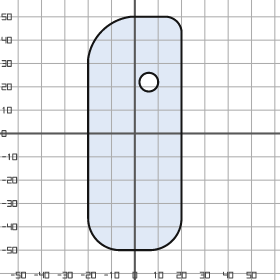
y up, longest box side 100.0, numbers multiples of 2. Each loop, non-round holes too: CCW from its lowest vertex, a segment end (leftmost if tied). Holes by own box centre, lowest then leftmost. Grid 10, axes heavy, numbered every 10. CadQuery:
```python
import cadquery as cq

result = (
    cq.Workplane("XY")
    .moveTo(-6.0, -50.0)
    .lineTo(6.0, -50.0)
    .threePointArc((16.0, -46.0), (20.0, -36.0))
    .lineTo(20.0, 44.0)
    .threePointArc((18.0, 48.0), (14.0, 50.0))
    .lineTo(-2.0, 50.0)
    .threePointArc((-14.0, 44.0), (-20.0, 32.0))
    .lineTo(-20.0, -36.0)
    .threePointArc((-16.0, -46.0), (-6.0, -50.0))
    .close()
    .moveTo(6.0, 22.0)
    .circle(4.0)
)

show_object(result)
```